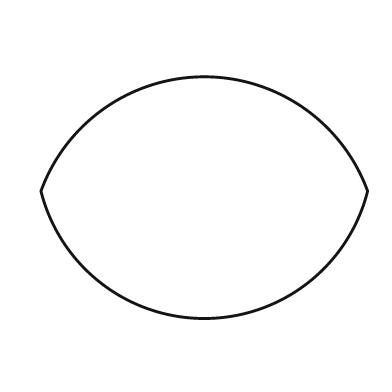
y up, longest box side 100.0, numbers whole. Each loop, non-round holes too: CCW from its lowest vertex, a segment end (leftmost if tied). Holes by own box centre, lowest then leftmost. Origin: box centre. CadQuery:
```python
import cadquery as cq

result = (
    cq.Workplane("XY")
    .moveTo(-50.0, 2.0)
    .threePointArc((0.0, -37.0), (50.0, 2.0))
    .threePointArc((0.0, 37.0), (-50.0, 2.0))
    .close()
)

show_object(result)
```